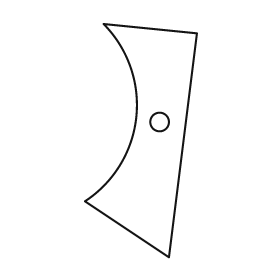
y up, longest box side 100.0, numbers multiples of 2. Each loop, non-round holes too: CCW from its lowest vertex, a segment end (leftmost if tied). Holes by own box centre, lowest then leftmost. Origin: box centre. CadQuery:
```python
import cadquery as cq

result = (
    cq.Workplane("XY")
    .moveTo(12.0, -50.0)
    .lineTo(24.0, 46.0)
    .lineTo(-16.0, 50.0)
    .threePointArc((-2.0, 10.0), (-24.0, -26.0))
    .close()
    .moveTo(8.0, 8.0)
    .circle(4.0)
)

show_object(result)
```